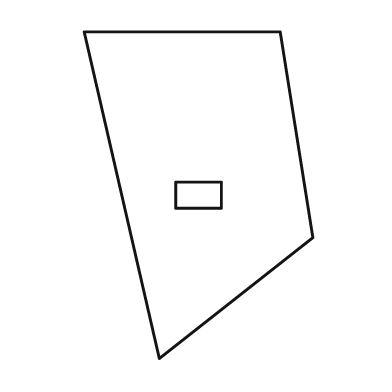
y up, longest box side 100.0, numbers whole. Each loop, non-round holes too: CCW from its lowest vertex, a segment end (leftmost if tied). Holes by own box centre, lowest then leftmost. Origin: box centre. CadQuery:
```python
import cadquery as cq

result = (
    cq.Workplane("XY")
    .moveTo(-12.0, -50.0)
    .lineTo(35.0, -13.0)
    .lineTo(25.0, 50.0)
    .lineTo(-35.0, 50.0)
    .close()
    .moveTo(-7.0, -4.0)
    .lineTo(7.0, -4.0)
    .lineTo(7.0, 4.0)
    .lineTo(-7.0, 4.0)
    .close()
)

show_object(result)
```